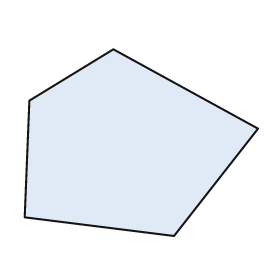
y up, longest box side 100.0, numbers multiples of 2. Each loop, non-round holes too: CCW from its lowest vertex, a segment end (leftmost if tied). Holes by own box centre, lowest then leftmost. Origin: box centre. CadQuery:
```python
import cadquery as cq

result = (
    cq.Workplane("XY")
    .moveTo(14.0, -40.0)
    .lineTo(50.0, 6.0)
    .lineTo(-12.0, 40.0)
    .lineTo(-48.0, 18.0)
    .lineTo(-50.0, -32.0)
    .close()
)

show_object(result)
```